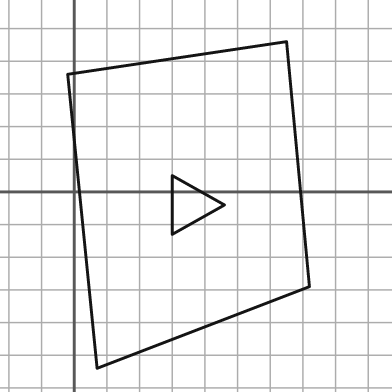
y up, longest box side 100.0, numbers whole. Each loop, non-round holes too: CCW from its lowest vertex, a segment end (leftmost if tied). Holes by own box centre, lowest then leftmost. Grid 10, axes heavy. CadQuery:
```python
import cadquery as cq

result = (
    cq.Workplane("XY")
    .moveTo(7.0, -54.0)
    .lineTo(72.0, -29.0)
    .lineTo(65.0, 46.0)
    .lineTo(-2.0, 36.0)
    .close()
    .moveTo(30.0, -13.0)
    .lineTo(46.0, -4.0)
    .lineTo(30.0, 5.0)
    .close()
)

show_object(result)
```